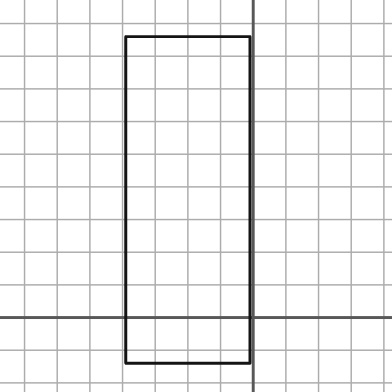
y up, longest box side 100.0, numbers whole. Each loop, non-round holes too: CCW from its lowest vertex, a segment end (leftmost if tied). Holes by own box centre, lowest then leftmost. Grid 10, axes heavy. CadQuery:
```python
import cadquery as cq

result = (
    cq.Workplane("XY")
    .moveTo(-39.0, -14.0)
    .lineTo(-1.0, -14.0)
    .lineTo(-1.0, 86.0)
    .lineTo(-39.0, 86.0)
    .close()
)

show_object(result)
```